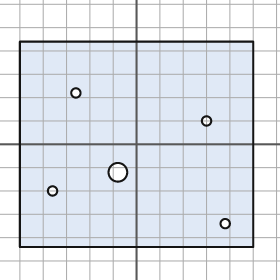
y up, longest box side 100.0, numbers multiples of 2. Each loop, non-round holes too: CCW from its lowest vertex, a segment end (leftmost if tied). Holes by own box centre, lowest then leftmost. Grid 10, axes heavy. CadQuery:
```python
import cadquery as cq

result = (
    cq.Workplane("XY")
    .moveTo(-50.0, -44.0)
    .lineTo(50.0, -44.0)
    .lineTo(50.0, 44.0)
    .lineTo(-50.0, 44.0)
    .close()
    .moveTo(38.0, -34.0)
    .circle(2.0)
    .moveTo(-36.0, -20.0)
    .circle(2.0)
    .moveTo(-8.0, -12.0)
    .circle(4.0)
    .moveTo(30.0, 10.0)
    .circle(2.0)
    .moveTo(-26.0, 22.0)
    .circle(2.0)
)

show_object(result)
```